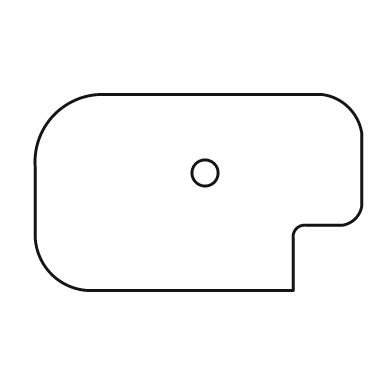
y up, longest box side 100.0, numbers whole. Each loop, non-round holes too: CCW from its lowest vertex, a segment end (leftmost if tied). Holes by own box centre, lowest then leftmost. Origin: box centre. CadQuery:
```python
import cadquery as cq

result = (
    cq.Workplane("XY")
    .moveTo(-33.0, -30.0)
    .lineTo(29.0, -30.0)
    .lineTo(29.0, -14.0)
    .threePointArc((30.0, -11.0), (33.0, -10.0))
    .lineTo(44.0, -10.0)
    .threePointArc((48.0, -8.0), (50.0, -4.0))
    .lineTo(50.0, 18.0)
    .threePointArc((46.0, 26.0), (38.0, 30.0))
    .lineTo(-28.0, 30.0)
    .threePointArc((-44.0, 24.0), (-50.0, 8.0))
    .lineTo(-50.0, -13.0)
    .threePointArc((-45.0, -25.0), (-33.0, -30.0))
    .close()
    .moveTo(2.0, 6.0)
    .circle(4.0)
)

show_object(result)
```